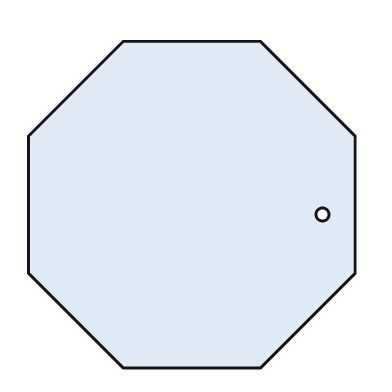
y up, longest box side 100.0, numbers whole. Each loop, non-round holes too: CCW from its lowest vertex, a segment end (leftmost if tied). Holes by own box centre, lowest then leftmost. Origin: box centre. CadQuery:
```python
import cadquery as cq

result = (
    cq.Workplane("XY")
    .moveTo(-21.0, -50.0)
    .lineTo(21.0, -50.0)
    .lineTo(50.0, -21.0)
    .lineTo(50.0, 21.0)
    .lineTo(21.0, 50.0)
    .lineTo(-21.0, 50.0)
    .lineTo(-50.0, 21.0)
    .lineTo(-50.0, -21.0)
    .close()
    .moveTo(40.0, -3.0)
    .circle(2.0)
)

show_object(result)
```